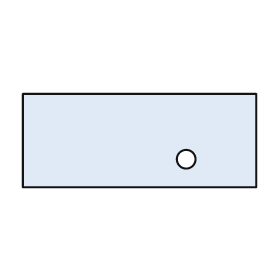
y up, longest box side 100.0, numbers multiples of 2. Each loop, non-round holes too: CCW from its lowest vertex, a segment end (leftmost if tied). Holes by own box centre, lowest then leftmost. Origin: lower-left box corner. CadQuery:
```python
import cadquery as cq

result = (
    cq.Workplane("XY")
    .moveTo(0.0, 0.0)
    .lineTo(100.0, 0.0)
    .lineTo(100.0, 40.0)
    .lineTo(0.0, 40.0)
    .close()
    .moveTo(70.0, 12.0)
    .circle(4.0)
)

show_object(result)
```